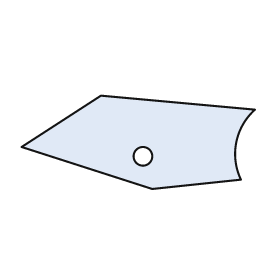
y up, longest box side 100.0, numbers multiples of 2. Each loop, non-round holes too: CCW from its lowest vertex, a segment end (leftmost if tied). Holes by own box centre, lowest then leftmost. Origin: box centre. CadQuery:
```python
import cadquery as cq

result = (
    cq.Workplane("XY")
    .moveTo(6.0, -20.0)
    .lineTo(44.0, -16.0)
    .threePointArc((42.0, 0.0), (50.0, 14.0))
    .lineTo(-16.0, 20.0)
    .lineTo(-50.0, -2.0)
    .close()
    .moveTo(2.0, -6.0)
    .circle(4.0)
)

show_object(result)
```